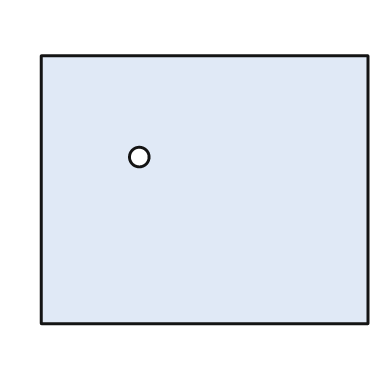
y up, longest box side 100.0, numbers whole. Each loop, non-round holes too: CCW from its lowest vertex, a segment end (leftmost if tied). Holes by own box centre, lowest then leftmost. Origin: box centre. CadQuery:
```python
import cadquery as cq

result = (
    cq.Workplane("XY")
    .moveTo(-50.0, -41.0)
    .lineTo(50.0, -41.0)
    .lineTo(50.0, 41.0)
    .lineTo(-50.0, 41.0)
    .close()
    .moveTo(-20.0, 10.0)
    .circle(3.0)
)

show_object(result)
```